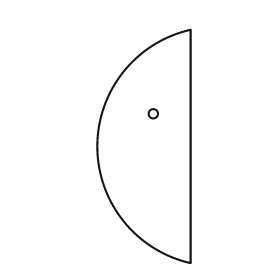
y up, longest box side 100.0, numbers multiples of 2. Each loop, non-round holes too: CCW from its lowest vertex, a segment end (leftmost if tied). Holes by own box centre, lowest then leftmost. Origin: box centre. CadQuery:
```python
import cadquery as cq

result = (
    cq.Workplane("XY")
    .moveTo(20.0, -50.0)
    .lineTo(20.0, 50.0)
    .threePointArc((-20.0, 0.0), (20.0, -50.0))
    .close()
    .moveTo(4.0, 14.0)
    .circle(2.0)
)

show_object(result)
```